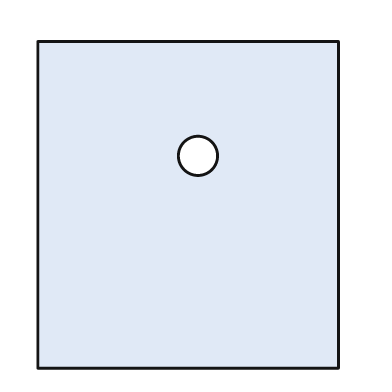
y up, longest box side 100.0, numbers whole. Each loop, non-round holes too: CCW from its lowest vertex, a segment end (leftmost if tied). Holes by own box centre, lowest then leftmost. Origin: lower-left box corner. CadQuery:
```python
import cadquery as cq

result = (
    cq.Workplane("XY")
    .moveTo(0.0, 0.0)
    .lineTo(92.0, 0.0)
    .lineTo(92.0, 100.0)
    .lineTo(0.0, 100.0)
    .close()
    .moveTo(49.0, 65.0)
    .circle(6.0)
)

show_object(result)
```